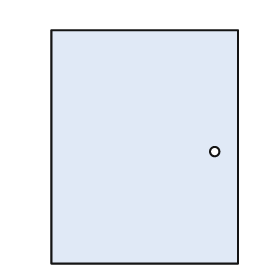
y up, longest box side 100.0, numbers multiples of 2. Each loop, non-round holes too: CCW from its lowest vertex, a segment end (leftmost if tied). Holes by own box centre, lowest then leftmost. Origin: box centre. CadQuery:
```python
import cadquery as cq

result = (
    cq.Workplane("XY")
    .moveTo(-40.0, -50.0)
    .lineTo(40.0, -50.0)
    .lineTo(40.0, 50.0)
    .lineTo(-40.0, 50.0)
    .close()
    .moveTo(30.0, -2.0)
    .circle(2.0)
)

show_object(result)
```